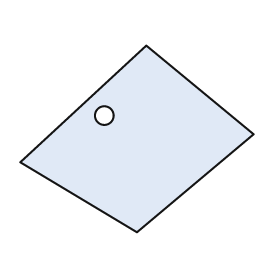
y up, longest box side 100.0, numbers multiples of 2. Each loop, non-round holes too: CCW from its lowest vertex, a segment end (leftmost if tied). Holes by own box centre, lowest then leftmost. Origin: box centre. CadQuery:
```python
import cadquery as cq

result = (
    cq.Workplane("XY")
    .moveTo(0.0, -40.0)
    .lineTo(50.0, 2.0)
    .lineTo(4.0, 40.0)
    .lineTo(-50.0, -10.0)
    .close()
    .moveTo(-14.0, 10.0)
    .circle(4.0)
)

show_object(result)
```